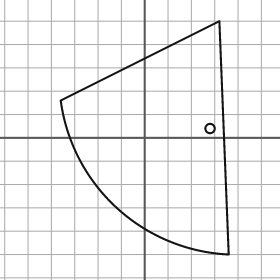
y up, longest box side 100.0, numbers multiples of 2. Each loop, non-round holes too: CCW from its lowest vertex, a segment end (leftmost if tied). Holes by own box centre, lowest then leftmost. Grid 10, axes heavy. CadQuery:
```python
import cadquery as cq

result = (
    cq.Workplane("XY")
    .moveTo(36.0, -50.0)
    .lineTo(32.0, 50.0)
    .lineTo(-36.0, 16.0)
    .threePointArc((-12.0, -30.0), (36.0, -50.0))
    .close()
    .moveTo(28.0, 4.0)
    .circle(2.0)
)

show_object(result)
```